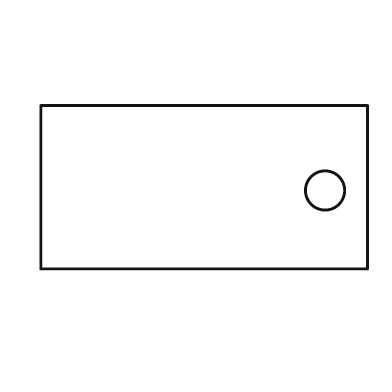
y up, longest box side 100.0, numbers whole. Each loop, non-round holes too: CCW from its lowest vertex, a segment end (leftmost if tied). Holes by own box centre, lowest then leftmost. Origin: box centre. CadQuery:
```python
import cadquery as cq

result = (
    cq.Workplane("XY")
    .moveTo(-50.0, -25.0)
    .lineTo(50.0, -25.0)
    .lineTo(50.0, 25.0)
    .lineTo(-50.0, 25.0)
    .close()
    .moveTo(37.0, -1.0)
    .circle(6.0)
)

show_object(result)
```